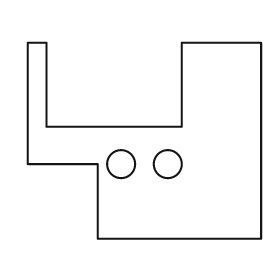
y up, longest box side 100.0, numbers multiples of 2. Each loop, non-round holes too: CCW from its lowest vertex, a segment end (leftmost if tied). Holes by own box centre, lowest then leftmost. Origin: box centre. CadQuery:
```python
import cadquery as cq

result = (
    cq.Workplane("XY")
    .moveTo(-20.0, -42.0)
    .lineTo(50.0, -42.0)
    .lineTo(50.0, 42.0)
    .lineTo(16.0, 42.0)
    .lineTo(16.0, 6.0)
    .lineTo(-42.0, 6.0)
    .lineTo(-42.0, 42.0)
    .lineTo(-50.0, 42.0)
    .lineTo(-50.0, -10.0)
    .lineTo(-20.0, -10.0)
    .close()
    .moveTo(-10.0, -10.0)
    .circle(6.0)
    .moveTo(10.0, -10.0)
    .circle(6.0)
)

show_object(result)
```